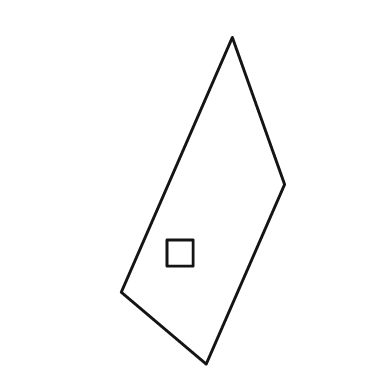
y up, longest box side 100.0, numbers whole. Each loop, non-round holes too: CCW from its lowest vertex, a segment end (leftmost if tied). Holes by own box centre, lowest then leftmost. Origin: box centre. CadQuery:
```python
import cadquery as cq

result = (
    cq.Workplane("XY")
    .moveTo(1.0, -50.0)
    .lineTo(25.0, 5.0)
    .lineTo(9.0, 50.0)
    .lineTo(-25.0, -28.0)
    .close()
    .moveTo(-11.0, -20.0)
    .lineTo(-3.0, -20.0)
    .lineTo(-3.0, -12.0)
    .lineTo(-11.0, -12.0)
    .close()
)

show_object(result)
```